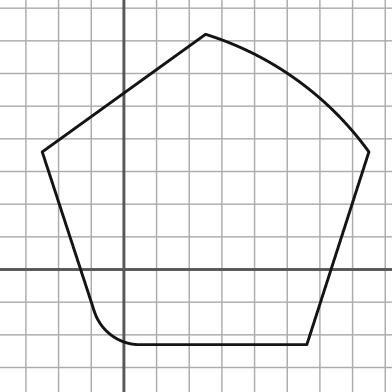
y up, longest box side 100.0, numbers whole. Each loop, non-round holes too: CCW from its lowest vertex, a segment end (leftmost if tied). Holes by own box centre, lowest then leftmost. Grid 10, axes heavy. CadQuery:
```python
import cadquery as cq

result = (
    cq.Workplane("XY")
    .moveTo(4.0, -23.0)
    .lineTo(56.0, -23.0)
    .lineTo(75.0, 36.0)
    .threePointArc((53.0, 58.0), (25.0, 72.0))
    .lineTo(-25.0, 36.0)
    .lineTo(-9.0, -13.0)
    .threePointArc((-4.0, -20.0), (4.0, -23.0))
    .close()
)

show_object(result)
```